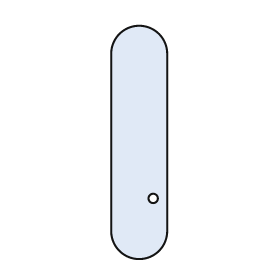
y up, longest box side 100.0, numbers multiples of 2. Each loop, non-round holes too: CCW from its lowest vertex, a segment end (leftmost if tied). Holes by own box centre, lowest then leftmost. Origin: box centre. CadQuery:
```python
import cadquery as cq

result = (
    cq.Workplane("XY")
    .moveTo(-12.0, -38.0)
    .threePointArc((0.0, -50.0), (12.0, -38.0))
    .lineTo(12.0, 38.0)
    .threePointArc((0.0, 50.0), (-12.0, 38.0))
    .close()
    .moveTo(6.0, -24.0)
    .circle(2.0)
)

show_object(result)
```